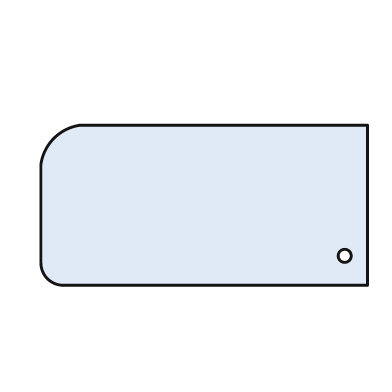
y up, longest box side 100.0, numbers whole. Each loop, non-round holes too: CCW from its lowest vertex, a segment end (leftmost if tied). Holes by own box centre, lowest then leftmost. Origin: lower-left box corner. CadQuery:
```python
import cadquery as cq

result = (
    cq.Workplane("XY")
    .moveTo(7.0, 0.0)
    .lineTo(100.0, 0.0)
    .lineTo(100.0, 49.0)
    .lineTo(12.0, 49.0)
    .threePointArc((4.0, 45.0), (0.0, 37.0))
    .lineTo(0.0, 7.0)
    .threePointArc((2.0, 2.0), (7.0, 0.0))
    .close()
    .moveTo(93.0, 9.0)
    .circle(2.0)
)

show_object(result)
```